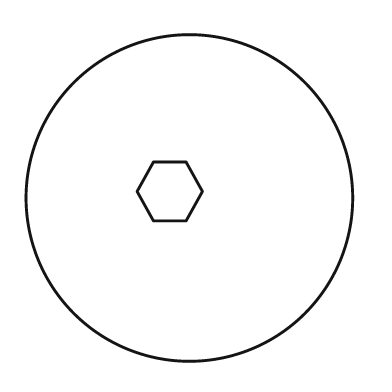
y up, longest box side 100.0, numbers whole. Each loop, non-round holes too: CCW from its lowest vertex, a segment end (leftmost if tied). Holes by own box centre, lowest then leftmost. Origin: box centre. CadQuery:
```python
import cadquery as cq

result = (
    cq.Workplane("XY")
    .moveTo(0.0, 0.0)
    .circle(50.0)
    .moveTo(-11.0, -7.0)
    .lineTo(-1.0, -7.0)
    .lineTo(4.0, 2.0)
    .lineTo(-1.0, 11.0)
    .lineTo(-11.0, 11.0)
    .lineTo(-16.0, 2.0)
    .close()
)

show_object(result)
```